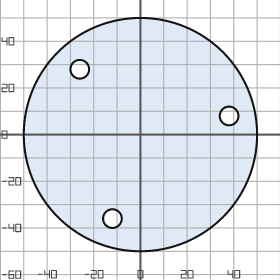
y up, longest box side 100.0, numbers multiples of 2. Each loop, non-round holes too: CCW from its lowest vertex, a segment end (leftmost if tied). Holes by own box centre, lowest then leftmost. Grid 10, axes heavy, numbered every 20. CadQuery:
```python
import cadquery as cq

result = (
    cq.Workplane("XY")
    .moveTo(0.0, 0.0)
    .circle(50.0)
    .moveTo(-12.0, -36.0)
    .circle(4.0)
    .moveTo(38.0, 8.0)
    .circle(4.0)
    .moveTo(-26.0, 28.0)
    .circle(4.0)
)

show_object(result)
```